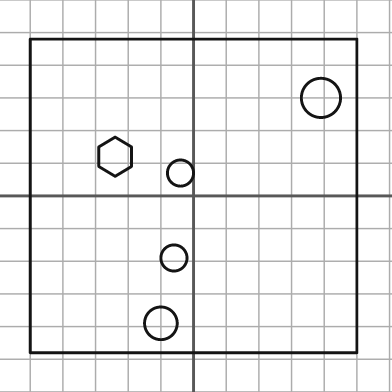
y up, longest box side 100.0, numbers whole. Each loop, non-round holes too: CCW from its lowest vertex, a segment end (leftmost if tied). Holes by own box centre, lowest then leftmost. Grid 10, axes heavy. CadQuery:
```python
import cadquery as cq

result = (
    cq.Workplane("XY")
    .moveTo(-50.0, -48.0)
    .lineTo(50.0, -48.0)
    .lineTo(50.0, 48.0)
    .lineTo(-50.0, 48.0)
    .close()
    .moveTo(-10.0, -39.0)
    .circle(5.0)
    .moveTo(-6.0, -19.0)
    .circle(4.0)
    .moveTo(-4.0, 7.0)
    .circle(4.0)
    .moveTo(-24.0, 6.0)
    .lineTo(-19.0, 9.0)
    .lineTo(-19.0, 15.0)
    .lineTo(-24.0, 18.0)
    .lineTo(-29.0, 15.0)
    .lineTo(-29.0, 9.0)
    .close()
    .moveTo(39.0, 30.0)
    .circle(6.0)
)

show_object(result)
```